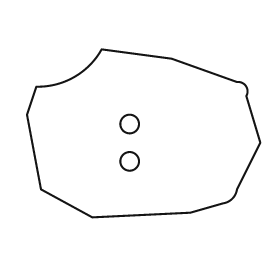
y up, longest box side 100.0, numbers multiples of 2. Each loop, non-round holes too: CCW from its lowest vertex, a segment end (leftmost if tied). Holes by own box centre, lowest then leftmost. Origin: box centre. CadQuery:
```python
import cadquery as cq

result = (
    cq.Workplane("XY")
    .moveTo(-22.0, -36.0)
    .lineTo(20.0, -34.0)
    .lineTo(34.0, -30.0)
    .threePointArc((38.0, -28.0), (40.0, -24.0))
    .lineTo(50.0, -4.0)
    .lineTo(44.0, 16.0)
    .threePointArc((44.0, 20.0), (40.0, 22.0))
    .lineTo(12.0, 32.0)
    .lineTo(-18.0, 36.0)
    .threePointArc((-30.0, 24.0), (-46.0, 20.0))
    .lineTo(-50.0, 8.0)
    .lineTo(-44.0, -24.0)
    .close()
    .moveTo(-6.0, -12.0)
    .circle(4.0)
    .moveTo(-6.0, 4.0)
    .circle(4.0)
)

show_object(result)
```